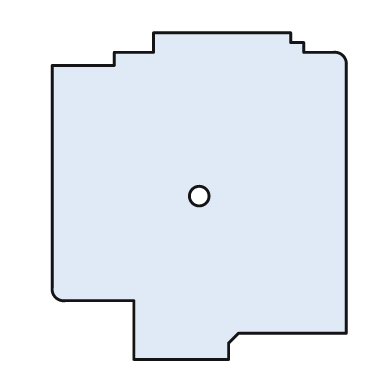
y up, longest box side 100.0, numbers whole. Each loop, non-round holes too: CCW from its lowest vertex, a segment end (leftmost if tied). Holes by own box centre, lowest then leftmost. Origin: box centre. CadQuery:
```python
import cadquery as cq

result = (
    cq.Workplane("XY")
    .moveTo(-20.0, -50.0)
    .lineTo(9.0, -50.0)
    .lineTo(9.0, -45.0)
    .lineTo(12.0, -42.0)
    .lineTo(45.0, -42.0)
    .lineTo(45.0, 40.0)
    .threePointArc((44.0, 43.0), (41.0, 44.0))
    .lineTo(32.0, 44.0)
    .lineTo(32.0, 47.0)
    .lineTo(28.0, 47.0)
    .lineTo(28.0, 50.0)
    .lineTo(-14.0, 50.0)
    .lineTo(-14.0, 44.0)
    .lineTo(-26.0, 44.0)
    .lineTo(-26.0, 40.0)
    .lineTo(-45.0, 40.0)
    .lineTo(-45.0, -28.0)
    .threePointArc((-44.0, -31.0), (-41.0, -32.0))
    .lineTo(-20.0, -32.0)
    .close()
    .moveTo(0.0, 0.0)
    .circle(3.0)
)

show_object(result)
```